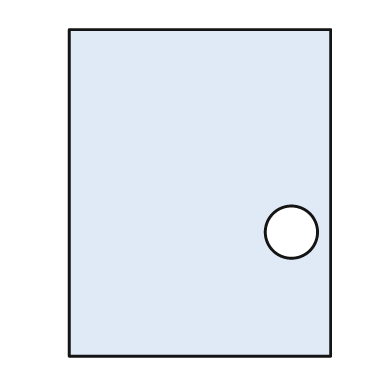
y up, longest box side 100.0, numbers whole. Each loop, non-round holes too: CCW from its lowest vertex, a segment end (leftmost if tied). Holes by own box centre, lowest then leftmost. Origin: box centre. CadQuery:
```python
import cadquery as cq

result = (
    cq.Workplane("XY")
    .moveTo(-40.0, -50.0)
    .lineTo(40.0, -50.0)
    .lineTo(40.0, 50.0)
    .lineTo(-40.0, 50.0)
    .close()
    .moveTo(28.0, -12.0)
    .circle(8.0)
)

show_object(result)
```